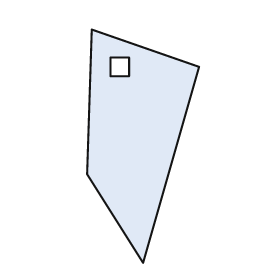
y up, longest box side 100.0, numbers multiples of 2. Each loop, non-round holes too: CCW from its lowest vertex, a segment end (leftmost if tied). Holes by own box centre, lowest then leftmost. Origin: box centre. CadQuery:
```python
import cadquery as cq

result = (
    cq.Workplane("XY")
    .moveTo(0.0, -50.0)
    .lineTo(24.0, 34.0)
    .lineTo(-22.0, 50.0)
    .lineTo(-24.0, -12.0)
    .close()
    .moveTo(-14.0, 30.0)
    .lineTo(-6.0, 30.0)
    .lineTo(-6.0, 38.0)
    .lineTo(-14.0, 38.0)
    .close()
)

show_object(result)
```